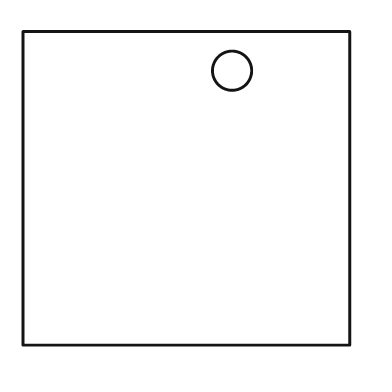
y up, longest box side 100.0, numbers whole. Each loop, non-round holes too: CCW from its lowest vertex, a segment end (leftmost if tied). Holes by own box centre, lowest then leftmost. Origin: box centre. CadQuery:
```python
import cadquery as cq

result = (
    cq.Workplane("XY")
    .moveTo(-50.0, -48.0)
    .lineTo(50.0, -48.0)
    .lineTo(50.0, 48.0)
    .lineTo(-50.0, 48.0)
    .close()
    .moveTo(14.0, 36.0)
    .circle(6.0)
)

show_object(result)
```